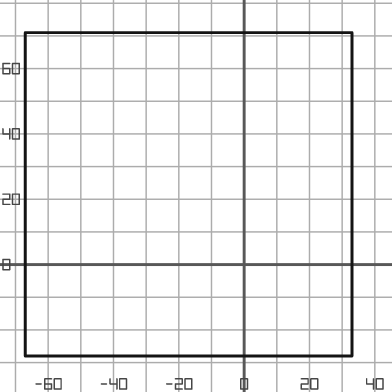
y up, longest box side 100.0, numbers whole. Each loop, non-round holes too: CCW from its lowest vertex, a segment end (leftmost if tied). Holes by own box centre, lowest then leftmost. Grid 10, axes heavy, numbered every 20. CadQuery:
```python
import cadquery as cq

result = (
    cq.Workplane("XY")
    .moveTo(-67.0, -28.0)
    .lineTo(33.0, -28.0)
    .lineTo(33.0, 71.0)
    .lineTo(-67.0, 71.0)
    .close()
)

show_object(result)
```